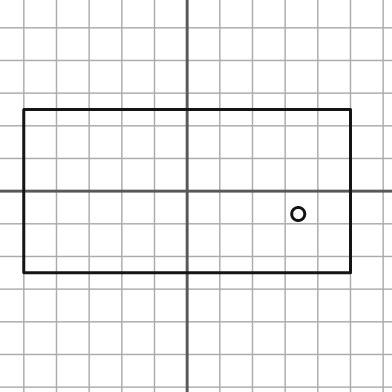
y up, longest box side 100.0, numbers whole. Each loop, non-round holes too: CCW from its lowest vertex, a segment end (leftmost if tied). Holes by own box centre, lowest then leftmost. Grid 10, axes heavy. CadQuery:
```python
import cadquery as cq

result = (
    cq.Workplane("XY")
    .moveTo(-50.0, -25.0)
    .lineTo(50.0, -25.0)
    .lineTo(50.0, 25.0)
    .lineTo(-50.0, 25.0)
    .close()
    .moveTo(34.0, -7.0)
    .circle(2.0)
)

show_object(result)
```